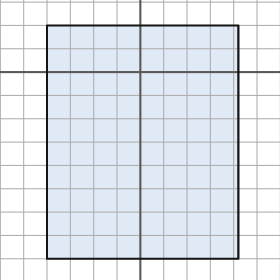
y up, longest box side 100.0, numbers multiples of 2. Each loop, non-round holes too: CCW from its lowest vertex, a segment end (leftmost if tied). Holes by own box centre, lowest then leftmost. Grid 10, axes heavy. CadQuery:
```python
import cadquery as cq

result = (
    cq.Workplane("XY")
    .moveTo(-40.0, -80.0)
    .lineTo(42.0, -80.0)
    .lineTo(42.0, 20.0)
    .lineTo(-40.0, 20.0)
    .close()
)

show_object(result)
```